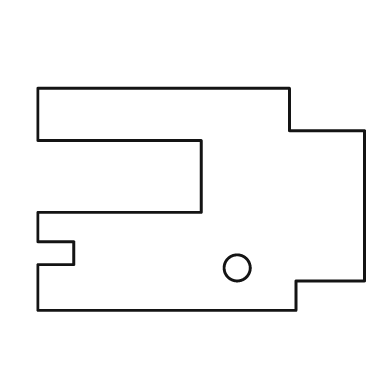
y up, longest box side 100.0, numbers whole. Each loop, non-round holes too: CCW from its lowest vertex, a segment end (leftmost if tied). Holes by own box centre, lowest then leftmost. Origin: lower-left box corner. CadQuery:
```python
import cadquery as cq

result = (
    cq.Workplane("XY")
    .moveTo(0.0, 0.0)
    .lineTo(79.0, 0.0)
    .lineTo(79.0, 9.0)
    .lineTo(100.0, 9.0)
    .lineTo(100.0, 55.0)
    .lineTo(77.0, 55.0)
    .lineTo(77.0, 68.0)
    .lineTo(0.0, 68.0)
    .lineTo(0.0, 52.0)
    .lineTo(50.0, 52.0)
    .lineTo(50.0, 30.0)
    .lineTo(0.0, 30.0)
    .lineTo(0.0, 21.0)
    .lineTo(11.0, 21.0)
    .lineTo(11.0, 14.0)
    .lineTo(0.0, 14.0)
    .close()
    .moveTo(61.0, 13.0)
    .circle(4.0)
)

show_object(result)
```